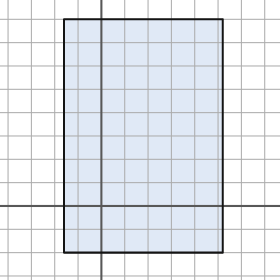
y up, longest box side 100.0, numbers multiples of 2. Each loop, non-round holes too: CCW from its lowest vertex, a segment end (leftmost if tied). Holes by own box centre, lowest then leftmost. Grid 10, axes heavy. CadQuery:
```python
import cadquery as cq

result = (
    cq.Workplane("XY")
    .moveTo(-16.0, -20.0)
    .lineTo(52.0, -20.0)
    .lineTo(52.0, 80.0)
    .lineTo(-16.0, 80.0)
    .close()
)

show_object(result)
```